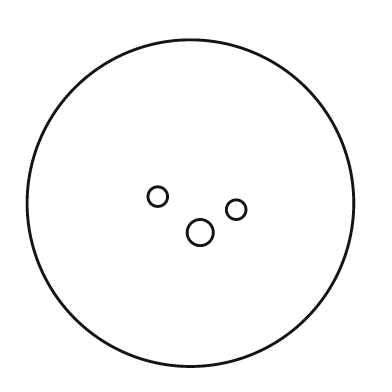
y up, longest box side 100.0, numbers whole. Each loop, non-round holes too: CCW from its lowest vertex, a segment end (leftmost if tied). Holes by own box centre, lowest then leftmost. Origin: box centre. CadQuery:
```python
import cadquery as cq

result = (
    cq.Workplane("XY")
    .moveTo(0.0, 0.0)
    .circle(50.0)
    .moveTo(3.0, -9.0)
    .circle(4.0)
    .moveTo(14.0, -2.0)
    .circle(3.0)
    .moveTo(-10.0, 2.0)
    .circle(3.0)
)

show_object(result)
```